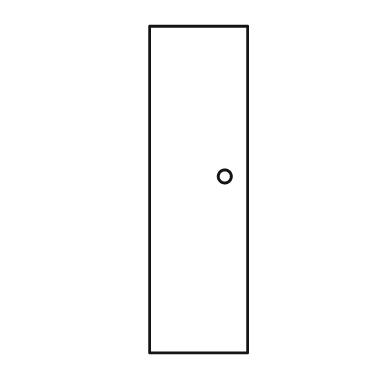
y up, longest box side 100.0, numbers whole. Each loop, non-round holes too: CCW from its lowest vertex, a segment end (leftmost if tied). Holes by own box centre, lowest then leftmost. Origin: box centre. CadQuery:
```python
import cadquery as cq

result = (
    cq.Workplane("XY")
    .moveTo(-15.0, -50.0)
    .lineTo(15.0, -50.0)
    .lineTo(15.0, 50.0)
    .lineTo(-15.0, 50.0)
    .close()
    .moveTo(8.0, 4.0)
    .circle(2.0)
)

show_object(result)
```